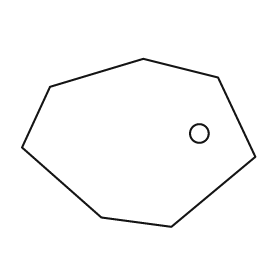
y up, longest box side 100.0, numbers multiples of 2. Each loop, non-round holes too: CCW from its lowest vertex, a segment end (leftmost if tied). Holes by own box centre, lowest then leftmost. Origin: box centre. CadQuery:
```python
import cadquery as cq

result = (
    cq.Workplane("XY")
    .moveTo(14.0, -36.0)
    .lineTo(50.0, -6.0)
    .lineTo(34.0, 28.0)
    .lineTo(2.0, 36.0)
    .lineTo(-38.0, 24.0)
    .lineTo(-50.0, -2.0)
    .lineTo(-16.0, -32.0)
    .close()
    .moveTo(26.0, 4.0)
    .circle(4.0)
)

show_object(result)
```